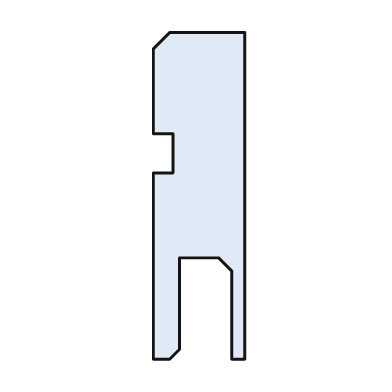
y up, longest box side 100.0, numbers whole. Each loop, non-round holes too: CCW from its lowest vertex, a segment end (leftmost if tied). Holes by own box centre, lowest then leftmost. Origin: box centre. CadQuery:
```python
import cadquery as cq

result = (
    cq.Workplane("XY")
    .moveTo(-14.0, -50.0)
    .lineTo(-9.0, -50.0)
    .lineTo(-6.0, -47.0)
    .lineTo(-6.0, -19.0)
    .lineTo(6.0, -19.0)
    .lineTo(10.0, -23.0)
    .lineTo(10.0, -50.0)
    .lineTo(14.0, -50.0)
    .lineTo(14.0, 50.0)
    .lineTo(-9.0, 50.0)
    .lineTo(-14.0, 45.0)
    .lineTo(-14.0, 19.0)
    .lineTo(-8.0, 19.0)
    .lineTo(-8.0, 7.0)
    .lineTo(-14.0, 7.0)
    .close()
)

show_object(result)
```